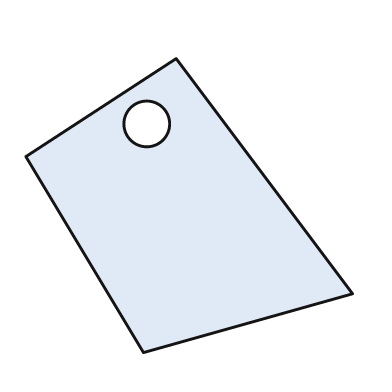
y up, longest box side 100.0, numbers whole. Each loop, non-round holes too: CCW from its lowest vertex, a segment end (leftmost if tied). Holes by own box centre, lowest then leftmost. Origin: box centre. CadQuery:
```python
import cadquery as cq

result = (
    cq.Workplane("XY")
    .moveTo(-14.0, -45.0)
    .lineTo(50.0, -27.0)
    .lineTo(-4.0, 45.0)
    .lineTo(-50.0, 15.0)
    .close()
    .moveTo(-13.0, 25.0)
    .circle(7.0)
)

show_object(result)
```